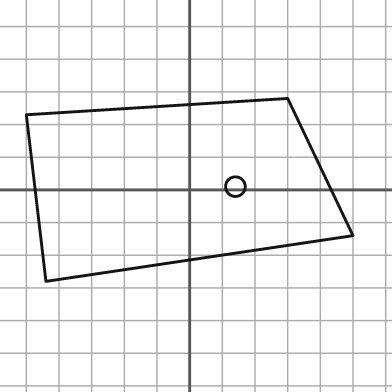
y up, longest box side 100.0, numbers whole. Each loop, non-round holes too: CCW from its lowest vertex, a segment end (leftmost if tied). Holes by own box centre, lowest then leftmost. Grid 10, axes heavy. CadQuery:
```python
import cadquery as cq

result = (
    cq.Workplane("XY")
    .moveTo(-44.0, -28.0)
    .lineTo(50.0, -14.0)
    .lineTo(30.0, 28.0)
    .lineTo(-50.0, 23.0)
    .close()
    .moveTo(14.0, 1.0)
    .circle(3.0)
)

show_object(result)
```